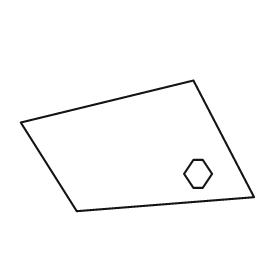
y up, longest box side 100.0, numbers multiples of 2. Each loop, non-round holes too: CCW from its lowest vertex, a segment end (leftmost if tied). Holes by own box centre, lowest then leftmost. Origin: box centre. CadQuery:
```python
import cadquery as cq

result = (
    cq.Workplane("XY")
    .moveTo(-26.0, -28.0)
    .lineTo(50.0, -22.0)
    .lineTo(24.0, 28.0)
    .lineTo(-50.0, 10.0)
    .close()
    .moveTo(24.0, -18.0)
    .lineTo(28.0, -18.0)
    .lineTo(32.0, -12.0)
    .lineTo(28.0, -6.0)
    .lineTo(24.0, -6.0)
    .lineTo(20.0, -12.0)
    .close()
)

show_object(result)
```